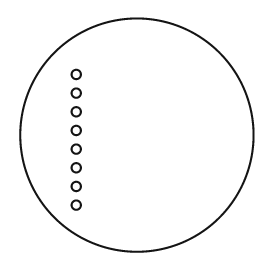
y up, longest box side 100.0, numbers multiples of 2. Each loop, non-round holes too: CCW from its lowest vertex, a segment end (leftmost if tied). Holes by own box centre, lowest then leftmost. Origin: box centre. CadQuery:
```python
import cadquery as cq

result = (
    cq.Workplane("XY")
    .moveTo(0.0, 0.0)
    .circle(50.0)
    .moveTo(-26.0, -30.0)
    .circle(2.0)
    .moveTo(-26.0, -22.0)
    .circle(2.0)
    .moveTo(-26.0, -14.0)
    .circle(2.0)
    .moveTo(-26.0, -6.0)
    .circle(2.0)
    .moveTo(-26.0, 2.0)
    .circle(2.0)
    .moveTo(-26.0, 10.0)
    .circle(2.0)
    .moveTo(-26.0, 18.0)
    .circle(2.0)
    .moveTo(-26.0, 26.0)
    .circle(2.0)
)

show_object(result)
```